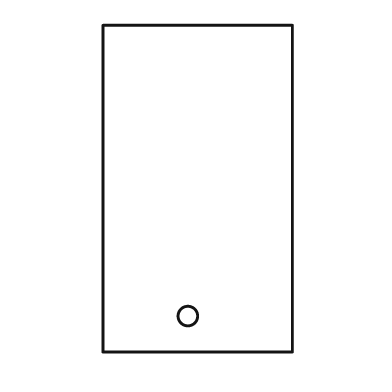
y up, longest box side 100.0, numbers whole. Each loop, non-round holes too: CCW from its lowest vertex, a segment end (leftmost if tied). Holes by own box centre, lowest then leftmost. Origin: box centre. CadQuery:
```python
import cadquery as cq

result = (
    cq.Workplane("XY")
    .moveTo(-29.0, -50.0)
    .lineTo(29.0, -50.0)
    .lineTo(29.0, 50.0)
    .lineTo(-29.0, 50.0)
    .close()
    .moveTo(-3.0, -39.0)
    .circle(3.0)
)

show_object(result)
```